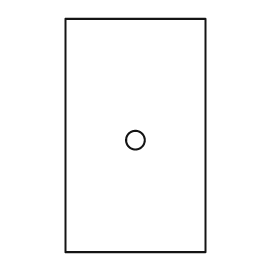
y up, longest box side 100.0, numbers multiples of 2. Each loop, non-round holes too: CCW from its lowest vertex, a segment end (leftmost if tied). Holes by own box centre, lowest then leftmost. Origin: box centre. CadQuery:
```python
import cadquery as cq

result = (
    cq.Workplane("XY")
    .moveTo(-30.0, -50.0)
    .lineTo(30.0, -50.0)
    .lineTo(30.0, 50.0)
    .lineTo(-30.0, 50.0)
    .close()
    .moveTo(0.0, -2.0)
    .circle(4.0)
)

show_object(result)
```